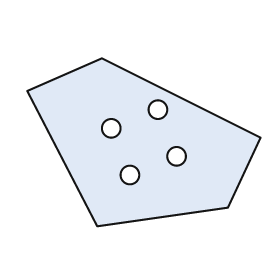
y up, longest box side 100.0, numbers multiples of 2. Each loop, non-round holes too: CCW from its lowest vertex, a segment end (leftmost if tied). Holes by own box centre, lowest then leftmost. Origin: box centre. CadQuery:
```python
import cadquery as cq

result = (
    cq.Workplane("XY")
    .moveTo(-20.0, -36.0)
    .lineTo(36.0, -28.0)
    .lineTo(50.0, 2.0)
    .lineTo(-18.0, 36.0)
    .lineTo(-50.0, 22.0)
    .close()
    .moveTo(-6.0, -14.0)
    .circle(4.0)
    .moveTo(14.0, -6.0)
    .circle(4.0)
    .moveTo(-14.0, 6.0)
    .circle(4.0)
    .moveTo(6.0, 14.0)
    .circle(4.0)
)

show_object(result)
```